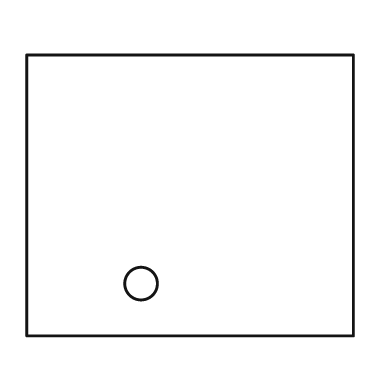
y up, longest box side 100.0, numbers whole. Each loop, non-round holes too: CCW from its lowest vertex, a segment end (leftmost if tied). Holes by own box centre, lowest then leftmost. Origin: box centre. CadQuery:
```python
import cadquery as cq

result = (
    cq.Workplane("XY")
    .moveTo(-50.0, -43.0)
    .lineTo(50.0, -43.0)
    .lineTo(50.0, 43.0)
    .lineTo(-50.0, 43.0)
    .close()
    .moveTo(-15.0, -27.0)
    .circle(5.0)
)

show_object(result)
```